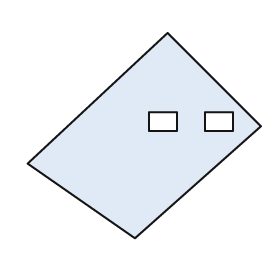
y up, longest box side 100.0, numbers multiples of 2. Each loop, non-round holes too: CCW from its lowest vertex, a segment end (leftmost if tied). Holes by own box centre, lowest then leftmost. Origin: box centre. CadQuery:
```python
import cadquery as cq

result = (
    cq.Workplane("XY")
    .moveTo(-4.0, -44.0)
    .lineTo(50.0, 4.0)
    .lineTo(10.0, 44.0)
    .lineTo(-50.0, -12.0)
    .close()
    .moveTo(2.0, 2.0)
    .lineTo(14.0, 2.0)
    .lineTo(14.0, 10.0)
    .lineTo(2.0, 10.0)
    .close()
    .moveTo(26.0, 2.0)
    .lineTo(38.0, 2.0)
    .lineTo(38.0, 10.0)
    .lineTo(26.0, 10.0)
    .close()
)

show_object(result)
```